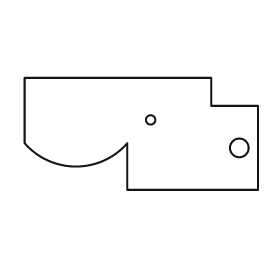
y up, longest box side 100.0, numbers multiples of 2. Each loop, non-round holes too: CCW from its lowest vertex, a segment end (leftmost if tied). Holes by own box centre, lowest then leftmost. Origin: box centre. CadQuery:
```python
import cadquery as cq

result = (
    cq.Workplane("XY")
    .moveTo(-6.0, -24.0)
    .lineTo(50.0, -24.0)
    .lineTo(50.0, 12.0)
    .lineTo(30.0, 12.0)
    .lineTo(30.0, 24.0)
    .lineTo(-50.0, 24.0)
    .lineTo(-50.0, -4.0)
    .threePointArc((-28.0, -14.0), (-6.0, -4.0))
    .close()
    .moveTo(42.0, -6.0)
    .circle(4.0)
    .moveTo(4.0, 6.0)
    .circle(2.0)
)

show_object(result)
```